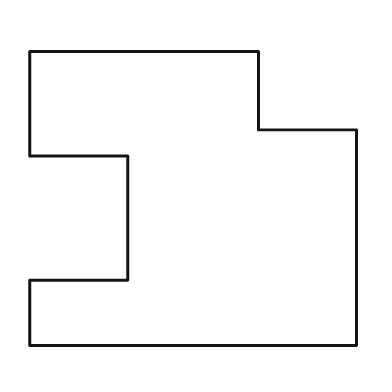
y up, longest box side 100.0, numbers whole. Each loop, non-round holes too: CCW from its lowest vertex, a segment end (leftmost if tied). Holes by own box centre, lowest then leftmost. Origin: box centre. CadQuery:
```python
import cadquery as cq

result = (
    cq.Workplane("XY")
    .moveTo(-50.0, -45.0)
    .lineTo(50.0, -45.0)
    .lineTo(50.0, 21.0)
    .lineTo(20.0, 21.0)
    .lineTo(20.0, 45.0)
    .lineTo(-50.0, 45.0)
    .lineTo(-50.0, 13.0)
    .lineTo(-20.0, 13.0)
    .lineTo(-20.0, -25.0)
    .lineTo(-50.0, -25.0)
    .close()
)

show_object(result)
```